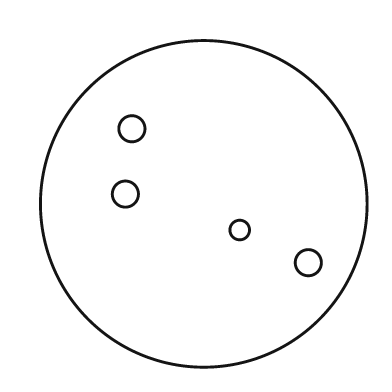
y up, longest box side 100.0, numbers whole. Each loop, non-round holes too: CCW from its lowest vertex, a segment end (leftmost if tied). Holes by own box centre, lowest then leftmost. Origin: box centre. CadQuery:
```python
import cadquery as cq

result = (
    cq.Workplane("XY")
    .moveTo(0.0, 0.0)
    .circle(50.0)
    .moveTo(32.0, -18.0)
    .circle(4.0)
    .moveTo(11.0, -8.0)
    .circle(3.0)
    .moveTo(-24.0, 3.0)
    .circle(4.0)
    .moveTo(-22.0, 23.0)
    .circle(4.0)
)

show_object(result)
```